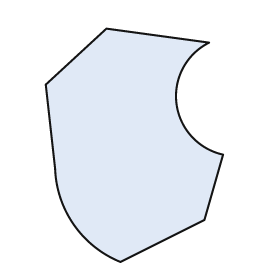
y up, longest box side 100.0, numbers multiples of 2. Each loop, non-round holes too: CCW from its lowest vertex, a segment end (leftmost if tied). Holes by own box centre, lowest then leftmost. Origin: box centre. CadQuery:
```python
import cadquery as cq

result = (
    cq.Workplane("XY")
    .moveTo(-6.0, -50.0)
    .lineTo(30.0, -32.0)
    .lineTo(38.0, -4.0)
    .threePointArc((18.0, 18.0), (32.0, 44.0))
    .lineTo(-12.0, 50.0)
    .lineTo(-38.0, 26.0)
    .lineTo(-34.0, -10.0)
    .threePointArc((-26.0, -34.0), (-6.0, -50.0))
    .close()
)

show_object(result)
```